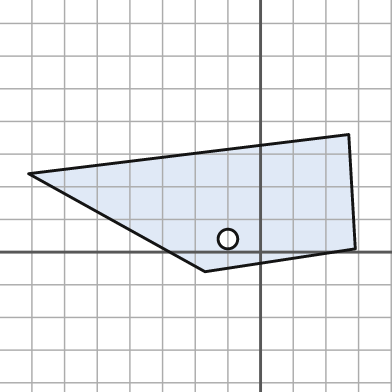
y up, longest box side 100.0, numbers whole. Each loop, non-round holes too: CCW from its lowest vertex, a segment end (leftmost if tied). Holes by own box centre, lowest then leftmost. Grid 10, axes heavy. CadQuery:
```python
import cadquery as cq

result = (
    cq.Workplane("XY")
    .moveTo(-17.0, -6.0)
    .lineTo(29.0, 1.0)
    .lineTo(27.0, 36.0)
    .lineTo(-71.0, 24.0)
    .close()
    .moveTo(-10.0, 4.0)
    .circle(3.0)
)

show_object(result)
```